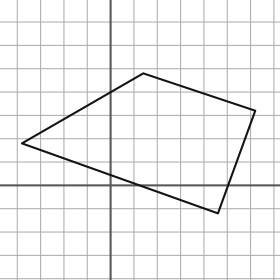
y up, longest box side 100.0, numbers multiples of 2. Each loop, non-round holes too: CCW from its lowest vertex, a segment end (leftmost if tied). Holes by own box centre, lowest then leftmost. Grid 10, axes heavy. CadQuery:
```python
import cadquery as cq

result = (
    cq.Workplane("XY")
    .moveTo(46.0, -12.0)
    .lineTo(62.0, 32.0)
    .lineTo(14.0, 48.0)
    .lineTo(-38.0, 18.0)
    .close()
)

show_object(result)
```